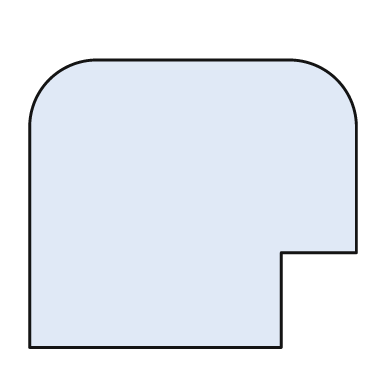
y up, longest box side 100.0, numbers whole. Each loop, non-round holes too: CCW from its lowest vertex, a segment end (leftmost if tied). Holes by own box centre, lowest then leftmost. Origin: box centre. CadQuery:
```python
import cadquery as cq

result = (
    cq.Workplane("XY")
    .moveTo(-50.0, -44.0)
    .lineTo(27.0, -44.0)
    .lineTo(27.0, -15.0)
    .lineTo(50.0, -15.0)
    .lineTo(50.0, 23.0)
    .threePointArc((44.0, 38.0), (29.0, 44.0))
    .lineTo(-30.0, 44.0)
    .threePointArc((-44.0, 38.0), (-50.0, 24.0))
    .close()
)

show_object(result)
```